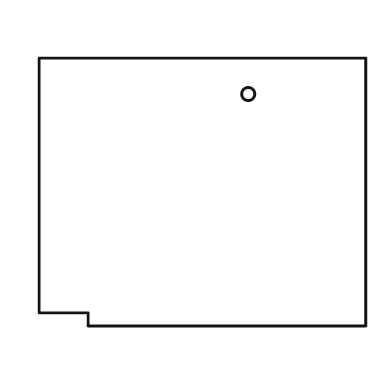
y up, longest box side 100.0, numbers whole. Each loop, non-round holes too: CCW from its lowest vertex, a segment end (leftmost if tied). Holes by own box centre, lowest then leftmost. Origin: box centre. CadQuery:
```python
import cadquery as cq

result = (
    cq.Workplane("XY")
    .moveTo(-35.0, -41.0)
    .lineTo(50.0, -41.0)
    .lineTo(50.0, 41.0)
    .lineTo(-50.0, 41.0)
    .lineTo(-50.0, -37.0)
    .lineTo(-35.0, -37.0)
    .close()
    .moveTo(14.0, 30.0)
    .circle(2.0)
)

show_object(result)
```